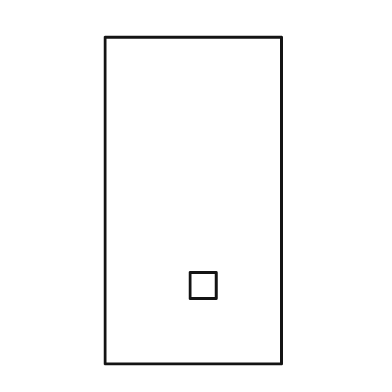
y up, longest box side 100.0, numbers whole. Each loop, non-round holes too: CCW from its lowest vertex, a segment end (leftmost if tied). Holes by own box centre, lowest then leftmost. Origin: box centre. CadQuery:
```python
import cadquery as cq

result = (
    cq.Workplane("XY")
    .moveTo(-27.0, -50.0)
    .lineTo(27.0, -50.0)
    .lineTo(27.0, 50.0)
    .lineTo(-27.0, 50.0)
    .close()
    .moveTo(-1.0, -30.0)
    .lineTo(7.0, -30.0)
    .lineTo(7.0, -22.0)
    .lineTo(-1.0, -22.0)
    .close()
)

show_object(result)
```